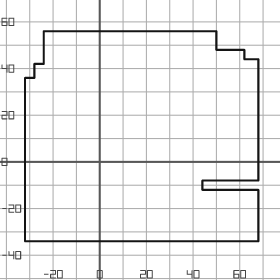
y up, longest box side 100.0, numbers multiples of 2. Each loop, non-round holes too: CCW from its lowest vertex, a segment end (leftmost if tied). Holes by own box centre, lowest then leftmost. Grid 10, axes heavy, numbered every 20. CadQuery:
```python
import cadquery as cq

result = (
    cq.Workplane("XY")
    .moveTo(-32.0, -34.0)
    .lineTo(68.0, -34.0)
    .lineTo(68.0, -12.0)
    .lineTo(44.0, -12.0)
    .lineTo(44.0, -8.0)
    .lineTo(68.0, -8.0)
    .lineTo(68.0, 44.0)
    .lineTo(62.0, 44.0)
    .lineTo(62.0, 48.0)
    .lineTo(50.0, 48.0)
    .lineTo(50.0, 56.0)
    .lineTo(-24.0, 56.0)
    .lineTo(-24.0, 42.0)
    .lineTo(-28.0, 42.0)
    .lineTo(-28.0, 36.0)
    .lineTo(-32.0, 36.0)
    .close()
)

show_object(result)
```